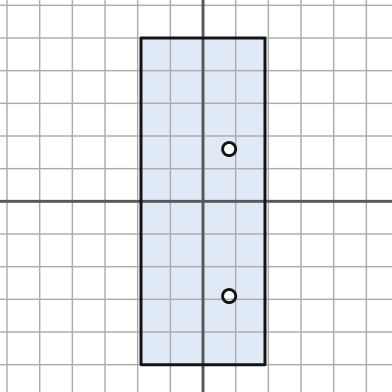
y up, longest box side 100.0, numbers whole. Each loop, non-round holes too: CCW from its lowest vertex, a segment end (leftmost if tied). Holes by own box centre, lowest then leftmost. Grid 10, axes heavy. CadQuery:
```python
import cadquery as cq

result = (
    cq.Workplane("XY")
    .moveTo(-19.0, -50.0)
    .lineTo(19.0, -50.0)
    .lineTo(19.0, 50.0)
    .lineTo(-19.0, 50.0)
    .close()
    .moveTo(8.0, -29.0)
    .circle(2.0)
    .moveTo(8.0, 16.0)
    .circle(2.0)
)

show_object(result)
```